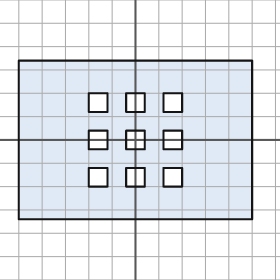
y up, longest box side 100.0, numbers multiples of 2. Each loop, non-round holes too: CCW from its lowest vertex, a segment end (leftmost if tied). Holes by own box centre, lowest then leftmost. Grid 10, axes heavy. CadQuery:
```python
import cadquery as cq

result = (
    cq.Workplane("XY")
    .moveTo(-50.0, -34.0)
    .lineTo(50.0, -34.0)
    .lineTo(50.0, 34.0)
    .lineTo(-50.0, 34.0)
    .close()
    .moveTo(-20.0, -20.0)
    .lineTo(-12.0, -20.0)
    .lineTo(-12.0, -12.0)
    .lineTo(-20.0, -12.0)
    .close()
    .moveTo(-4.0, -20.0)
    .lineTo(4.0, -20.0)
    .lineTo(4.0, -12.0)
    .lineTo(-4.0, -12.0)
    .close()
    .moveTo(12.0, -20.0)
    .lineTo(20.0, -20.0)
    .lineTo(20.0, -12.0)
    .lineTo(12.0, -12.0)
    .close()
    .moveTo(-20.0, -4.0)
    .lineTo(-12.0, -4.0)
    .lineTo(-12.0, 4.0)
    .lineTo(-20.0, 4.0)
    .close()
    .moveTo(-4.0, -4.0)
    .lineTo(4.0, -4.0)
    .lineTo(4.0, 4.0)
    .lineTo(-4.0, 4.0)
    .close()
    .moveTo(12.0, -4.0)
    .lineTo(20.0, -4.0)
    .lineTo(20.0, 4.0)
    .lineTo(12.0, 4.0)
    .close()
    .moveTo(-20.0, 12.0)
    .lineTo(-12.0, 12.0)
    .lineTo(-12.0, 20.0)
    .lineTo(-20.0, 20.0)
    .close()
    .moveTo(-4.0, 12.0)
    .lineTo(4.0, 12.0)
    .lineTo(4.0, 20.0)
    .lineTo(-4.0, 20.0)
    .close()
    .moveTo(12.0, 12.0)
    .lineTo(20.0, 12.0)
    .lineTo(20.0, 20.0)
    .lineTo(12.0, 20.0)
    .close()
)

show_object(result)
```